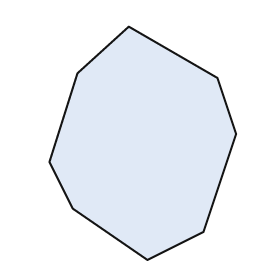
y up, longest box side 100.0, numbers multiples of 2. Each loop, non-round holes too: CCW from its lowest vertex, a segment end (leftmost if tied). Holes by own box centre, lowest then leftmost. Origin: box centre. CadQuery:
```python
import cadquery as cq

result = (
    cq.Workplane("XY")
    .moveTo(2.0, -50.0)
    .lineTo(26.0, -38.0)
    .lineTo(40.0, 4.0)
    .lineTo(32.0, 28.0)
    .lineTo(-6.0, 50.0)
    .lineTo(-28.0, 30.0)
    .lineTo(-40.0, -8.0)
    .lineTo(-30.0, -28.0)
    .close()
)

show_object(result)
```